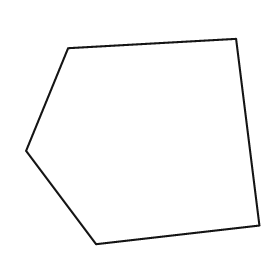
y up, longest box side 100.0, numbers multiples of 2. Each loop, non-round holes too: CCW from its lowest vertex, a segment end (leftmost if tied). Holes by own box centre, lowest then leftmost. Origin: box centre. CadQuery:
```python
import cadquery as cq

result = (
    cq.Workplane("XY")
    .moveTo(-20.0, -44.0)
    .lineTo(50.0, -36.0)
    .lineTo(40.0, 44.0)
    .lineTo(-32.0, 40.0)
    .lineTo(-50.0, -4.0)
    .close()
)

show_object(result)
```